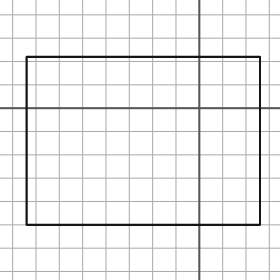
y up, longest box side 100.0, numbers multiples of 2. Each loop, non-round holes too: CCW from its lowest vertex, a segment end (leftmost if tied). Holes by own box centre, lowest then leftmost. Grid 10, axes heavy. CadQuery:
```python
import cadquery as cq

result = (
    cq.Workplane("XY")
    .moveTo(-74.0, -50.0)
    .lineTo(26.0, -50.0)
    .lineTo(26.0, 22.0)
    .lineTo(-74.0, 22.0)
    .close()
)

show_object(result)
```